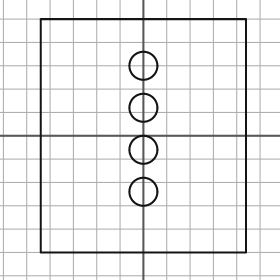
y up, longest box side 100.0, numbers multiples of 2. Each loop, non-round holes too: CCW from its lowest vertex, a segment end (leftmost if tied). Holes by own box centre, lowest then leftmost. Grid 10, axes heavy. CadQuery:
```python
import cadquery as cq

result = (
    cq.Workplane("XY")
    .moveTo(-44.0, -50.0)
    .lineTo(44.0, -50.0)
    .lineTo(44.0, 50.0)
    .lineTo(-44.0, 50.0)
    .close()
    .moveTo(0.0, -24.0)
    .circle(6.0)
    .moveTo(0.0, -6.0)
    .circle(6.0)
    .moveTo(0.0, 12.0)
    .circle(6.0)
    .moveTo(0.0, 30.0)
    .circle(6.0)
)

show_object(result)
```